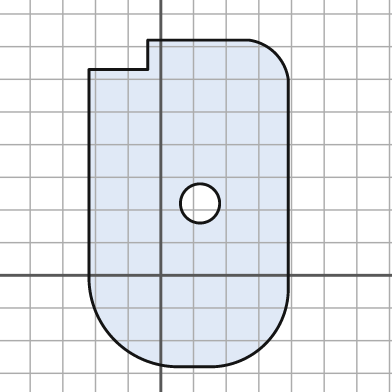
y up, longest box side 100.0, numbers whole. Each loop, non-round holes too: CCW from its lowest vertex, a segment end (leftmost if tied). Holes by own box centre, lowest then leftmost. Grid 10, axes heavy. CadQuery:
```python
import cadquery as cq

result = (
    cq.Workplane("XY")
    .moveTo(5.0, -28.0)
    .lineTo(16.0, -28.0)
    .threePointArc((32.0, -21.0), (39.0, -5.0))
    .lineTo(39.0, 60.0)
    .threePointArc((35.0, 68.0), (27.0, 72.0))
    .lineTo(-4.0, 72.0)
    .lineTo(-4.0, 63.0)
    .lineTo(-22.0, 63.0)
    .lineTo(-22.0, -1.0)
    .threePointArc((-14.0, -20.0), (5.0, -28.0))
    .close()
    .moveTo(12.0, 22.0)
    .circle(6.0)
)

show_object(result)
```